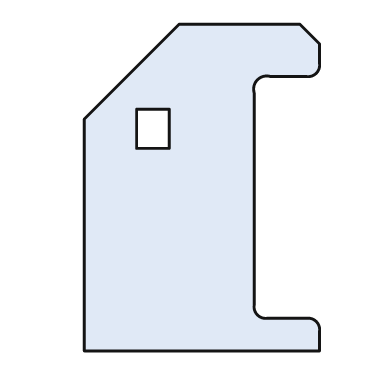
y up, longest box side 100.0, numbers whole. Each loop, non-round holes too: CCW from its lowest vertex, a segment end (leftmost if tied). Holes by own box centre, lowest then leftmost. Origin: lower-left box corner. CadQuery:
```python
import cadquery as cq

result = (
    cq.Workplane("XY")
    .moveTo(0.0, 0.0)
    .lineTo(72.0, 0.0)
    .lineTo(72.0, 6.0)
    .threePointArc((71.0, 9.0), (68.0, 10.0))
    .lineTo(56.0, 10.0)
    .threePointArc((53.0, 11.0), (52.0, 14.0))
    .lineTo(52.0, 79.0)
    .threePointArc((53.0, 83.0), (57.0, 84.0))
    .lineTo(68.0, 84.0)
    .threePointArc((71.0, 85.0), (72.0, 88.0))
    .lineTo(72.0, 94.0)
    .lineTo(66.0, 100.0)
    .lineTo(29.0, 100.0)
    .lineTo(0.0, 71.0)
    .close()
    .moveTo(16.0, 62.0)
    .lineTo(26.0, 62.0)
    .lineTo(26.0, 74.0)
    .lineTo(16.0, 74.0)
    .close()
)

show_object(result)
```